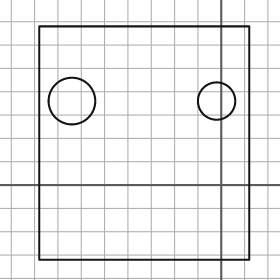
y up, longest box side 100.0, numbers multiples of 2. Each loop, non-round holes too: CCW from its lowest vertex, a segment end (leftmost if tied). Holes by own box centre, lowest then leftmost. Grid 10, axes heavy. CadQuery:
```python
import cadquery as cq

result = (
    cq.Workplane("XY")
    .moveTo(-78.0, -32.0)
    .lineTo(12.0, -32.0)
    .lineTo(12.0, 68.0)
    .lineTo(-78.0, 68.0)
    .close()
    .moveTo(-64.0, 36.0)
    .circle(10.0)
    .moveTo(-2.0, 36.0)
    .circle(8.0)
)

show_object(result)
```